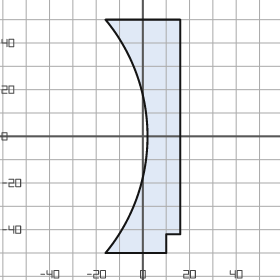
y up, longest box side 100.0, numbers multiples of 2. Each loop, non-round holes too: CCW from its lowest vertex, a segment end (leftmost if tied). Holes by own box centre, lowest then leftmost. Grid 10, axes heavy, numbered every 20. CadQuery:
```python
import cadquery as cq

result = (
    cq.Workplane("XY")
    .moveTo(-16.0, -50.0)
    .lineTo(10.0, -50.0)
    .lineTo(10.0, -42.0)
    .lineTo(16.0, -42.0)
    .lineTo(16.0, 50.0)
    .lineTo(-16.0, 50.0)
    .threePointArc((2.0, 0.0), (-16.0, -50.0))
    .close()
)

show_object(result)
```